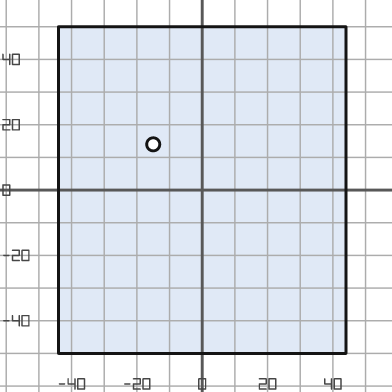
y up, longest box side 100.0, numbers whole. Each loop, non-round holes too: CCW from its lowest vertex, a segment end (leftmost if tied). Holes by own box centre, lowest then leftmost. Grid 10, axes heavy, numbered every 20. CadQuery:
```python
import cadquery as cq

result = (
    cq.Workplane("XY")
    .moveTo(-44.0, -50.0)
    .lineTo(44.0, -50.0)
    .lineTo(44.0, 50.0)
    .lineTo(-44.0, 50.0)
    .close()
    .moveTo(-15.0, 14.0)
    .circle(2.0)
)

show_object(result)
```